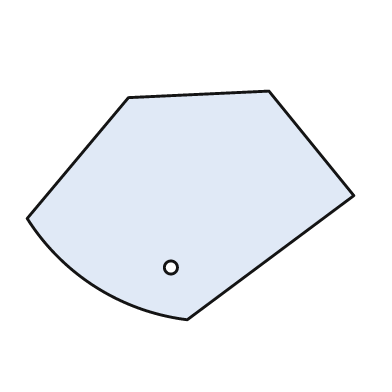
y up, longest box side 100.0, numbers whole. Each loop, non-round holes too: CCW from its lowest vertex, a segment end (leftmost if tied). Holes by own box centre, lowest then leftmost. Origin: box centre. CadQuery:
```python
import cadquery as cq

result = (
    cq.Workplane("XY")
    .moveTo(-1.0, -35.0)
    .lineTo(50.0, 3.0)
    .lineTo(24.0, 35.0)
    .lineTo(-19.0, 33.0)
    .lineTo(-50.0, -4.0)
    .threePointArc((-29.0, -25.0), (-1.0, -35.0))
    .close()
    .moveTo(-6.0, -19.0)
    .circle(2.0)
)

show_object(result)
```